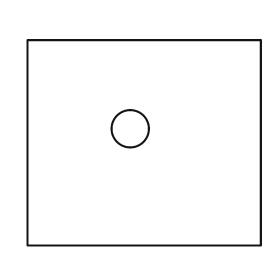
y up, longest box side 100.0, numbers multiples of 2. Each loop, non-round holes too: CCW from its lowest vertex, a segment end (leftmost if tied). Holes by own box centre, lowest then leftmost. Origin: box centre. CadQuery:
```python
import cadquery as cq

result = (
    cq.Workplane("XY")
    .moveTo(-50.0, -44.0)
    .lineTo(50.0, -44.0)
    .lineTo(50.0, 44.0)
    .lineTo(-50.0, 44.0)
    .close()
    .moveTo(-6.0, 6.0)
    .circle(8.0)
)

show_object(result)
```